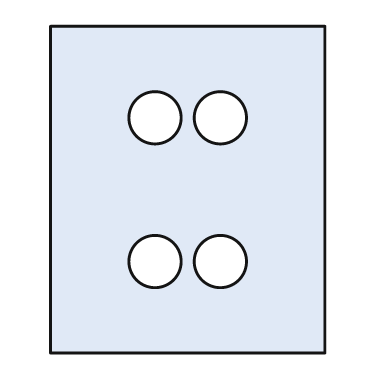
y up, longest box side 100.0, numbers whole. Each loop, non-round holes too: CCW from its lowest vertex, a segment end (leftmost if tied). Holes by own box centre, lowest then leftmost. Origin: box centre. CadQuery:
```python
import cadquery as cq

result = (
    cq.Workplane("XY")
    .moveTo(-42.0, -50.0)
    .lineTo(42.0, -50.0)
    .lineTo(42.0, 50.0)
    .lineTo(-42.0, 50.0)
    .close()
    .moveTo(-10.0, -22.0)
    .circle(8.0)
    .moveTo(10.0, -22.0)
    .circle(8.0)
    .moveTo(-10.0, 22.0)
    .circle(8.0)
    .moveTo(10.0, 22.0)
    .circle(8.0)
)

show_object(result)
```